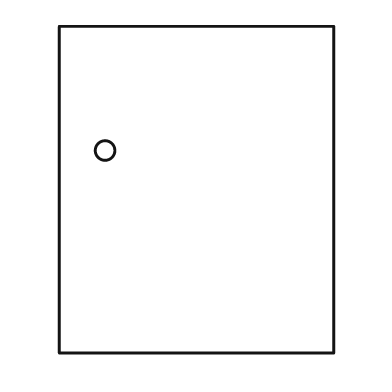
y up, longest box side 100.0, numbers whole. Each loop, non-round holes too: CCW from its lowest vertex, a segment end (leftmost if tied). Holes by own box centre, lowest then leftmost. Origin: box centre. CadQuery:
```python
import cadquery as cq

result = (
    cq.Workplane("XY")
    .moveTo(-42.0, -50.0)
    .lineTo(42.0, -50.0)
    .lineTo(42.0, 50.0)
    .lineTo(-42.0, 50.0)
    .close()
    .moveTo(-28.0, 12.0)
    .circle(3.0)
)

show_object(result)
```